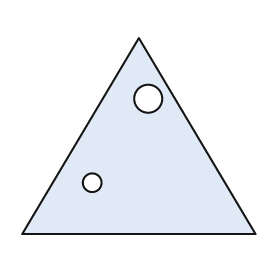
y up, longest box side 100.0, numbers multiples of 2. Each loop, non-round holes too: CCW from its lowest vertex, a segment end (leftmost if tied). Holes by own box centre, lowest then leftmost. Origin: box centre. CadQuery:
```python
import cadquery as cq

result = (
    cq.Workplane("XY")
    .moveTo(-50.0, -42.0)
    .lineTo(50.0, -42.0)
    .lineTo(0.0, 42.0)
    .close()
    .moveTo(-20.0, -20.0)
    .circle(4.0)
    .moveTo(4.0, 16.0)
    .circle(6.0)
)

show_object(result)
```